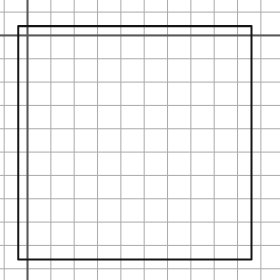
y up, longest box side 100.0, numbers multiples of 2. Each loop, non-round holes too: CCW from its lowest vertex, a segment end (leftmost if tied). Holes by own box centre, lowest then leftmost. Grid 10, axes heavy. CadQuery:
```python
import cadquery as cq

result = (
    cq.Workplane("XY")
    .moveTo(-4.0, -96.0)
    .lineTo(96.0, -96.0)
    .lineTo(96.0, 4.0)
    .lineTo(-4.0, 4.0)
    .close()
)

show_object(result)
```